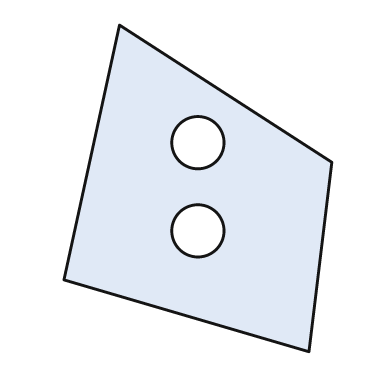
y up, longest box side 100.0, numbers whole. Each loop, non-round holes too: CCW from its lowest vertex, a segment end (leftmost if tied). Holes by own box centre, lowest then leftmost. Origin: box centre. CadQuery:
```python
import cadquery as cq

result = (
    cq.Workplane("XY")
    .moveTo(34.0, -50.0)
    .lineTo(41.0, 8.0)
    .lineTo(-24.0, 50.0)
    .lineTo(-41.0, -28.0)
    .close()
    .moveTo(0.0, -13.0)
    .circle(8.0)
    .moveTo(0.0, 14.0)
    .circle(8.0)
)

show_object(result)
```